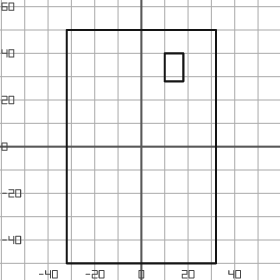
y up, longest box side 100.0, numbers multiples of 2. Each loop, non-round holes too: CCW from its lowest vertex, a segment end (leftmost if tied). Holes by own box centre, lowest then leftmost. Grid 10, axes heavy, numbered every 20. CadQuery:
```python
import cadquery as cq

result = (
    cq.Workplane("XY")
    .moveTo(-32.0, -50.0)
    .lineTo(32.0, -50.0)
    .lineTo(32.0, 50.0)
    .lineTo(-32.0, 50.0)
    .close()
    .moveTo(10.0, 28.0)
    .lineTo(18.0, 28.0)
    .lineTo(18.0, 40.0)
    .lineTo(10.0, 40.0)
    .close()
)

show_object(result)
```